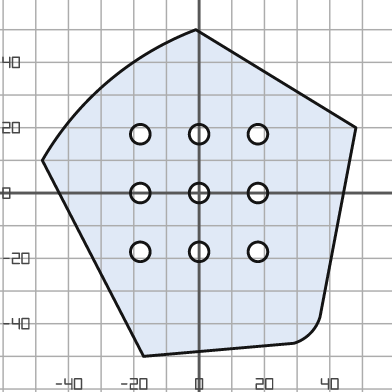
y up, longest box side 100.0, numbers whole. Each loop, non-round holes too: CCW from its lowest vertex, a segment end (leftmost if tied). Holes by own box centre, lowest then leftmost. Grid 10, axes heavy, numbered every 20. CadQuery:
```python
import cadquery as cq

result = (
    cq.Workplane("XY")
    .moveTo(-17.0, -50.0)
    .lineTo(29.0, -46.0)
    .threePointArc((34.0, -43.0), (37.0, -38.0))
    .lineTo(48.0, 20.0)
    .lineTo(-1.0, 50.0)
    .threePointArc((-28.0, 34.0), (-48.0, 10.0))
    .close()
    .moveTo(-18.0, -18.0)
    .circle(3.0)
    .moveTo(0.0, -18.0)
    .circle(3.0)
    .moveTo(18.0, -18.0)
    .circle(3.0)
    .moveTo(-18.0, 0.0)
    .circle(3.0)
    .moveTo(0.0, 0.0)
    .circle(3.0)
    .moveTo(18.0, 0.0)
    .circle(3.0)
    .moveTo(-18.0, 18.0)
    .circle(3.0)
    .moveTo(0.0, 18.0)
    .circle(3.0)
    .moveTo(18.0, 18.0)
    .circle(3.0)
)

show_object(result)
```